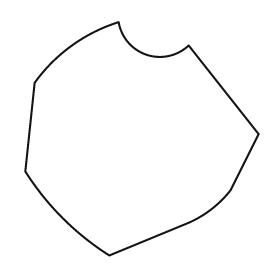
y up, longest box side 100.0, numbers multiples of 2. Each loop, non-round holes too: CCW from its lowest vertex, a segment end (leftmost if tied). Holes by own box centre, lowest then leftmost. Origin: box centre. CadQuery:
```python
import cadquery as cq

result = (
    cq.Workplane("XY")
    .moveTo(-14.0, -50.0)
    .lineTo(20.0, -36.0)
    .threePointArc((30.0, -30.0), (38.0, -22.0))
    .lineTo(50.0, 2.0)
    .lineTo(20.0, 40.0)
    .threePointArc((2.0, 36.0), (-10.0, 50.0))
    .threePointArc((-30.0, 40.0), (-46.0, 24.0))
    .lineTo(-50.0, -14.0)
    .threePointArc((-34.0, -34.0), (-14.0, -50.0))
    .close()
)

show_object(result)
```